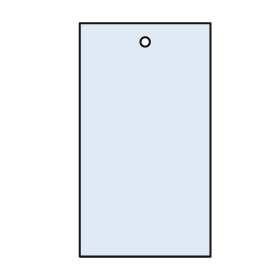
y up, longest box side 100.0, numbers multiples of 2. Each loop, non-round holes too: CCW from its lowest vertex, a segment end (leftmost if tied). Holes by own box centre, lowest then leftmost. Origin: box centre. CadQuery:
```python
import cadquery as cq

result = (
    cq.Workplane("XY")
    .moveTo(-28.0, -50.0)
    .lineTo(28.0, -50.0)
    .lineTo(28.0, 50.0)
    .lineTo(-28.0, 50.0)
    .close()
    .moveTo(0.0, 42.0)
    .circle(2.0)
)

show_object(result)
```